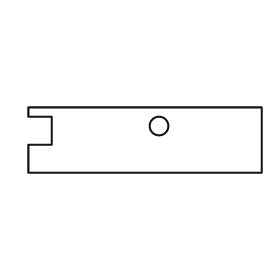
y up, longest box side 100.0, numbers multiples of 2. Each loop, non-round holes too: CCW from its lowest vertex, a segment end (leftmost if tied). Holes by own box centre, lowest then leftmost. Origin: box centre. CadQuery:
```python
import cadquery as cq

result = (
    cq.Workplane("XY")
    .moveTo(-50.0, -14.0)
    .lineTo(50.0, -14.0)
    .lineTo(50.0, 14.0)
    .lineTo(-50.0, 14.0)
    .lineTo(-50.0, 10.0)
    .lineTo(-40.0, 10.0)
    .lineTo(-40.0, -2.0)
    .lineTo(-50.0, -2.0)
    .close()
    .moveTo(6.0, 6.0)
    .circle(4.0)
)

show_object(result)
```